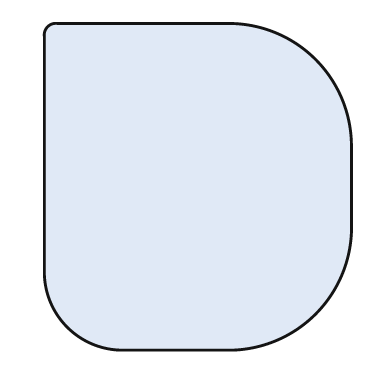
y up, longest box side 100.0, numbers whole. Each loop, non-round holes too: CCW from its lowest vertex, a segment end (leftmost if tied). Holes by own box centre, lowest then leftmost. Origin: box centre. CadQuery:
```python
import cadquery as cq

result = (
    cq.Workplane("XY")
    .moveTo(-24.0, -50.0)
    .lineTo(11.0, -50.0)
    .threePointArc((36.0, -39.0), (47.0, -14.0))
    .lineTo(47.0, 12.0)
    .threePointArc((36.0, 39.0), (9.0, 50.0))
    .lineTo(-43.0, 50.0)
    .threePointArc((-46.0, 49.0), (-47.0, 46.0))
    .lineTo(-47.0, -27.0)
    .threePointArc((-40.0, -43.0), (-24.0, -50.0))
    .close()
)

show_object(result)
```